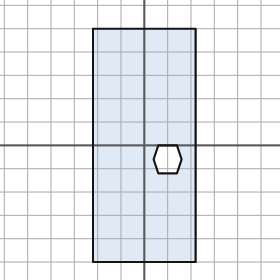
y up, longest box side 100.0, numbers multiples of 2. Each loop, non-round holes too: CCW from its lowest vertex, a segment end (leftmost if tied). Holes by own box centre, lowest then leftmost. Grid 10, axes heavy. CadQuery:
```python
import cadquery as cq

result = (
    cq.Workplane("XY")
    .moveTo(-22.0, -50.0)
    .lineTo(22.0, -50.0)
    .lineTo(22.0, 50.0)
    .lineTo(-22.0, 50.0)
    .close()
    .moveTo(6.0, -12.0)
    .lineTo(14.0, -12.0)
    .lineTo(16.0, -6.0)
    .lineTo(14.0, 0.0)
    .lineTo(6.0, 0.0)
    .lineTo(4.0, -6.0)
    .close()
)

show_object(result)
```